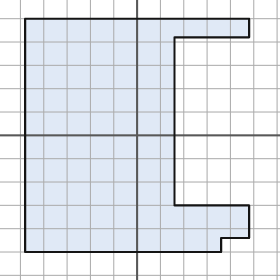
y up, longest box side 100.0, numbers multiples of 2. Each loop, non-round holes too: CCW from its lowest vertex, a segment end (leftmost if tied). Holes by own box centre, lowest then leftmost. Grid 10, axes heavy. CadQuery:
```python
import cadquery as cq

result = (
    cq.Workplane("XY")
    .moveTo(-48.0, -50.0)
    .lineTo(36.0, -50.0)
    .lineTo(36.0, -44.0)
    .lineTo(48.0, -44.0)
    .lineTo(48.0, -30.0)
    .lineTo(16.0, -30.0)
    .lineTo(16.0, 42.0)
    .lineTo(48.0, 42.0)
    .lineTo(48.0, 50.0)
    .lineTo(-48.0, 50.0)
    .close()
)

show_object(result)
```